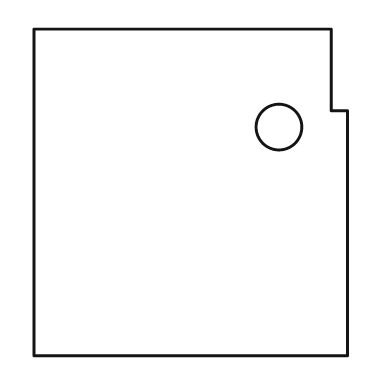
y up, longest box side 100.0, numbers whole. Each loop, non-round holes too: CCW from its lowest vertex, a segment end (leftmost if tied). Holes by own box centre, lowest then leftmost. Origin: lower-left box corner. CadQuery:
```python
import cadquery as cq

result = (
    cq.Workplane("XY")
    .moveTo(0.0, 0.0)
    .lineTo(96.0, 0.0)
    .lineTo(96.0, 75.0)
    .lineTo(91.0, 75.0)
    .lineTo(91.0, 100.0)
    .lineTo(0.0, 100.0)
    .close()
    .moveTo(75.0, 70.0)
    .circle(7.0)
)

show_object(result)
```